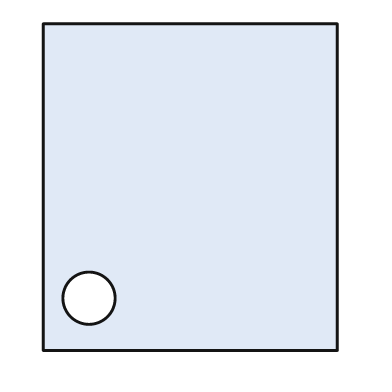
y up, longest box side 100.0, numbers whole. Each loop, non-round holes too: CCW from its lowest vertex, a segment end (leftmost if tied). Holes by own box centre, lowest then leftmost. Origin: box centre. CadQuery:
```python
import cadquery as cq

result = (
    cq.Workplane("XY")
    .moveTo(-45.0, -50.0)
    .lineTo(45.0, -50.0)
    .lineTo(45.0, 50.0)
    .lineTo(-45.0, 50.0)
    .close()
    .moveTo(-31.0, -34.0)
    .circle(8.0)
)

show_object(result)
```